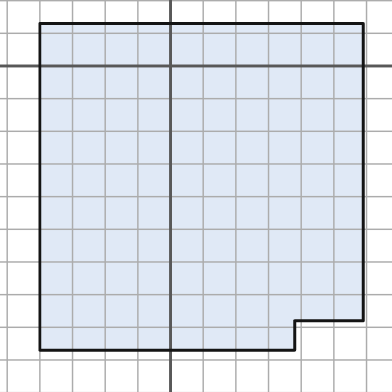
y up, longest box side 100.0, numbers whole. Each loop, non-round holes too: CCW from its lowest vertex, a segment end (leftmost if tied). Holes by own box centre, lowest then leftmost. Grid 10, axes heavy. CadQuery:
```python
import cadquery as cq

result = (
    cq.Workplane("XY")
    .moveTo(-40.0, -87.0)
    .lineTo(38.0, -87.0)
    .lineTo(38.0, -78.0)
    .lineTo(59.0, -78.0)
    .lineTo(59.0, 13.0)
    .lineTo(-40.0, 13.0)
    .close()
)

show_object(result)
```